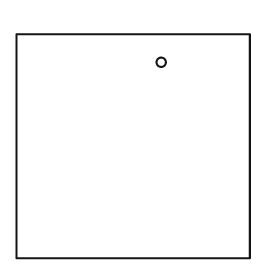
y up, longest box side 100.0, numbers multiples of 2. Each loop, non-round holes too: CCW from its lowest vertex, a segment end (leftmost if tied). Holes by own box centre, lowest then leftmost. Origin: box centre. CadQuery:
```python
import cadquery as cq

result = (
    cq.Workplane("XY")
    .moveTo(-50.0, -48.0)
    .lineTo(50.0, -48.0)
    .lineTo(50.0, 48.0)
    .lineTo(-50.0, 48.0)
    .close()
    .moveTo(12.0, 36.0)
    .circle(2.0)
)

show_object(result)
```